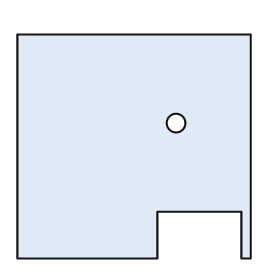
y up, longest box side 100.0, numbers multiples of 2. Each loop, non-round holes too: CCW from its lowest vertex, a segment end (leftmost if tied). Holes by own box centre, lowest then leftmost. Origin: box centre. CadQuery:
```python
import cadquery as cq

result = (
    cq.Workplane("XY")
    .moveTo(-50.0, -48.0)
    .lineTo(10.0, -48.0)
    .lineTo(10.0, -28.0)
    .lineTo(46.0, -28.0)
    .lineTo(46.0, -48.0)
    .lineTo(50.0, -48.0)
    .lineTo(50.0, 48.0)
    .lineTo(-50.0, 48.0)
    .close()
    .moveTo(18.0, 10.0)
    .circle(4.0)
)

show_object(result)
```